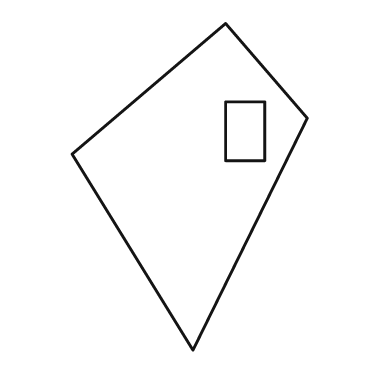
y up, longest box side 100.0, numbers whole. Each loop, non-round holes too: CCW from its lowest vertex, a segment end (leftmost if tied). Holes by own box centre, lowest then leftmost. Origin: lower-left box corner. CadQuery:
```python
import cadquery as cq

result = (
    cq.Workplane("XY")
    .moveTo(37.0, 0.0)
    .lineTo(72.0, 71.0)
    .lineTo(47.0, 100.0)
    .lineTo(0.0, 60.0)
    .close()
    .moveTo(47.0, 58.0)
    .lineTo(59.0, 58.0)
    .lineTo(59.0, 76.0)
    .lineTo(47.0, 76.0)
    .close()
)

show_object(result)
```